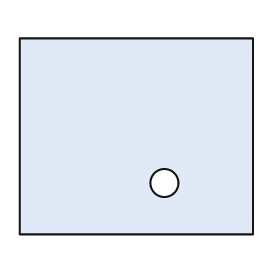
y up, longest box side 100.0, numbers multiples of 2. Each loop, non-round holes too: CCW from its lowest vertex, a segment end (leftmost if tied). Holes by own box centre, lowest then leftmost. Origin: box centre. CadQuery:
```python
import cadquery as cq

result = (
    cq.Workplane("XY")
    .moveTo(-50.0, -42.0)
    .lineTo(50.0, -42.0)
    .lineTo(50.0, 42.0)
    .lineTo(-50.0, 42.0)
    .close()
    .moveTo(12.0, -20.0)
    .circle(6.0)
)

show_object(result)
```